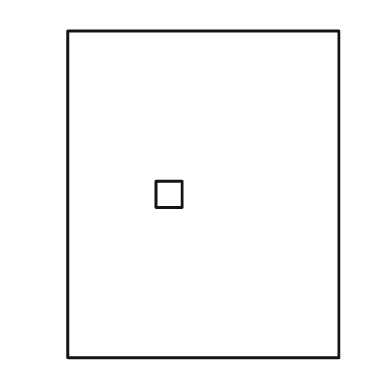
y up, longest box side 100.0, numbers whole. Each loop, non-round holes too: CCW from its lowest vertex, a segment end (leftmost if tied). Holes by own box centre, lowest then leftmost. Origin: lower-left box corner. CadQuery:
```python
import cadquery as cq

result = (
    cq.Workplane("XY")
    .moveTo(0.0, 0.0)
    .lineTo(83.0, 0.0)
    .lineTo(83.0, 100.0)
    .lineTo(0.0, 100.0)
    .close()
    .moveTo(27.0, 46.0)
    .lineTo(35.0, 46.0)
    .lineTo(35.0, 54.0)
    .lineTo(27.0, 54.0)
    .close()
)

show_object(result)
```